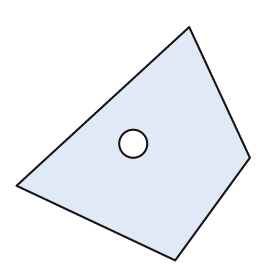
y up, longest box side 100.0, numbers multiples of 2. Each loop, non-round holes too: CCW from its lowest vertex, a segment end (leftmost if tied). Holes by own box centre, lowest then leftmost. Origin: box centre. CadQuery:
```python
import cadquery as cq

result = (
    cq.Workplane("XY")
    .moveTo(18.0, -50.0)
    .lineTo(50.0, -6.0)
    .lineTo(24.0, 50.0)
    .lineTo(-50.0, -18.0)
    .close()
    .moveTo(0.0, 0.0)
    .circle(6.0)
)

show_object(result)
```